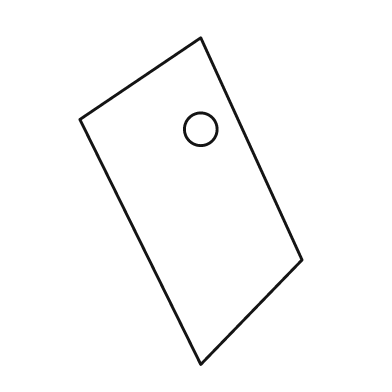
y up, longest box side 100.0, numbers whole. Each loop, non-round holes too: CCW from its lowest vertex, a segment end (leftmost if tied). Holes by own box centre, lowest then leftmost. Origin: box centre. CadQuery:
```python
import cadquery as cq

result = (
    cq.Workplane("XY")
    .moveTo(3.0, -50.0)
    .lineTo(34.0, -18.0)
    .lineTo(3.0, 50.0)
    .lineTo(-34.0, 25.0)
    .close()
    .moveTo(3.0, 22.0)
    .circle(5.0)
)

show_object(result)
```